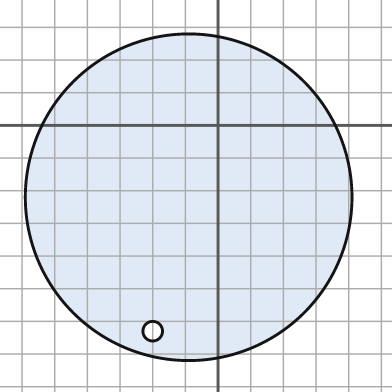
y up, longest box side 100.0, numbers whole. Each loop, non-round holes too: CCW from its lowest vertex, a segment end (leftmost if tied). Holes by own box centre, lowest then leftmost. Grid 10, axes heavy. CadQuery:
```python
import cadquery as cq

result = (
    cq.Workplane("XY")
    .moveTo(-9.0, -22.0)
    .circle(50.0)
    .moveTo(-20.0, -63.0)
    .circle(3.0)
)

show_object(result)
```